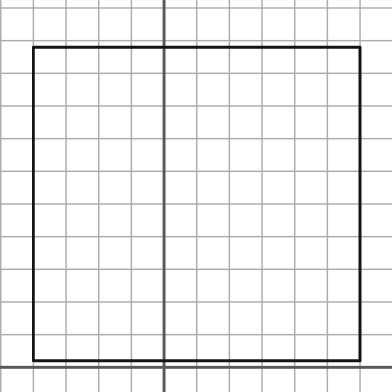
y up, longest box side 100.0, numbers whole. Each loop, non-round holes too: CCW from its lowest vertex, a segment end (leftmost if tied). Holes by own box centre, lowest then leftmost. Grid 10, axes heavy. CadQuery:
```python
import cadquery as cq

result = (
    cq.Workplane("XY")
    .moveTo(-40.0, 2.0)
    .lineTo(60.0, 2.0)
    .lineTo(60.0, 98.0)
    .lineTo(-40.0, 98.0)
    .close()
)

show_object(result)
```